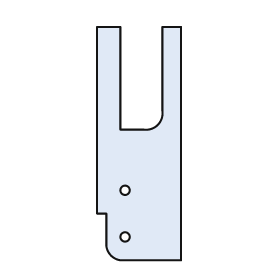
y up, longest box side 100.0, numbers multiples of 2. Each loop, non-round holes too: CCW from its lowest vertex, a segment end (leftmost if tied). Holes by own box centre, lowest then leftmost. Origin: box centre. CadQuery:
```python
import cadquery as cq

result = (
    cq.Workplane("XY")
    .moveTo(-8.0, -50.0)
    .lineTo(18.0, -50.0)
    .lineTo(18.0, 50.0)
    .lineTo(10.0, 50.0)
    .lineTo(10.0, 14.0)
    .threePointArc((8.0, 8.0), (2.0, 6.0))
    .lineTo(-8.0, 6.0)
    .lineTo(-8.0, 50.0)
    .lineTo(-18.0, 50.0)
    .lineTo(-18.0, -30.0)
    .lineTo(-14.0, -30.0)
    .lineTo(-14.0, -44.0)
    .threePointArc((-12.0, -48.0), (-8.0, -50.0))
    .close()
    .moveTo(-6.0, -40.0)
    .circle(2.0)
    .moveTo(-6.0, -20.0)
    .circle(2.0)
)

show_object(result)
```